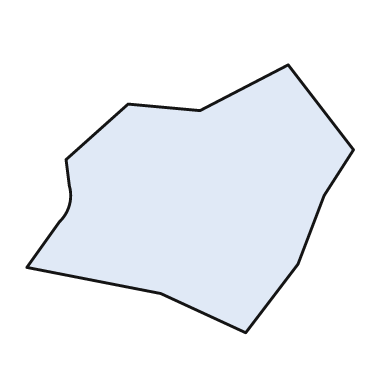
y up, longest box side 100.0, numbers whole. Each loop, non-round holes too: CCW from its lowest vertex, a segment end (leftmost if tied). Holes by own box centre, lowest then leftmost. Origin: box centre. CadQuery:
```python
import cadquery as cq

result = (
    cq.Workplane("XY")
    .moveTo(17.0, -41.0)
    .lineTo(33.0, -20.0)
    .lineTo(41.0, 1.0)
    .lineTo(50.0, 15.0)
    .lineTo(30.0, 41.0)
    .lineTo(3.0, 27.0)
    .lineTo(-19.0, 29.0)
    .lineTo(-38.0, 12.0)
    .lineTo(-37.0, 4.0)
    .threePointArc((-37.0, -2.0), (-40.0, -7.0))
    .lineTo(-50.0, -21.0)
    .lineTo(-9.0, -29.0)
    .close()
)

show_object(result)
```